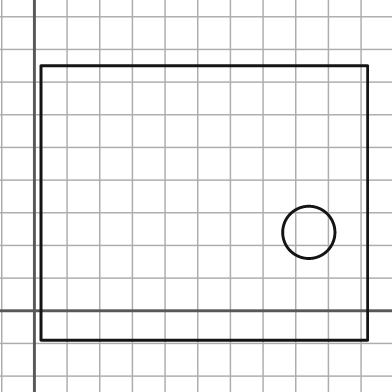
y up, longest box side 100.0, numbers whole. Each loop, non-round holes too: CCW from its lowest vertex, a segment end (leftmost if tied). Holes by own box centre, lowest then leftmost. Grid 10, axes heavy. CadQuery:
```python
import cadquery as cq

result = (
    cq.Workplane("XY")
    .moveTo(2.0, -9.0)
    .lineTo(102.0, -9.0)
    .lineTo(102.0, 75.0)
    .lineTo(2.0, 75.0)
    .close()
    .moveTo(84.0, 24.0)
    .circle(8.0)
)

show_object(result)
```